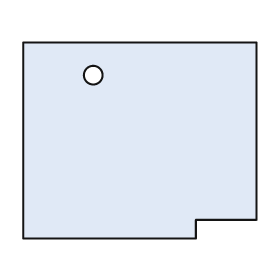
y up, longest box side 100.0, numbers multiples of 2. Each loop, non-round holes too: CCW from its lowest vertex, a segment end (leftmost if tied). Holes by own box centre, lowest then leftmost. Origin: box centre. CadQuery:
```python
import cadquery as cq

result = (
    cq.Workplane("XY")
    .moveTo(-50.0, -42.0)
    .lineTo(24.0, -42.0)
    .lineTo(24.0, -34.0)
    .lineTo(50.0, -34.0)
    .lineTo(50.0, 42.0)
    .lineTo(-50.0, 42.0)
    .close()
    .moveTo(-20.0, 28.0)
    .circle(4.0)
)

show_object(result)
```